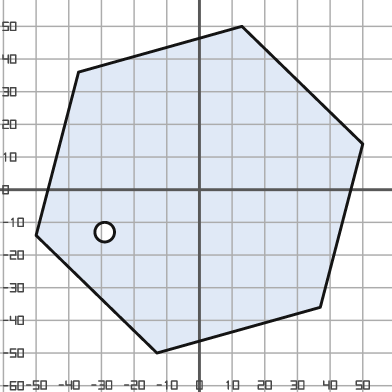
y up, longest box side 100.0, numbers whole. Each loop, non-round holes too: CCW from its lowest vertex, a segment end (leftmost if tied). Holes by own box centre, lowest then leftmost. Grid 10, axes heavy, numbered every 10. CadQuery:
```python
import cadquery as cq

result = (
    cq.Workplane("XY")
    .moveTo(-13.0, -50.0)
    .lineTo(37.0, -36.0)
    .lineTo(50.0, 14.0)
    .lineTo(13.0, 50.0)
    .lineTo(-37.0, 36.0)
    .lineTo(-50.0, -14.0)
    .close()
    .moveTo(-29.0, -13.0)
    .circle(3.0)
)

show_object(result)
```